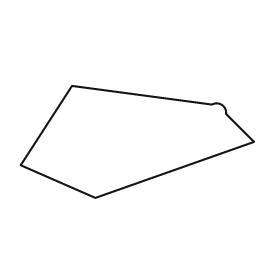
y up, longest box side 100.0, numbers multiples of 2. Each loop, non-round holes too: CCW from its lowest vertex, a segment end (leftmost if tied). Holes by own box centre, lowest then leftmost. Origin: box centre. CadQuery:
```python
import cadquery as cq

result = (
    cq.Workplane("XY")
    .moveTo(-18.0, -24.0)
    .lineTo(50.0, 0.0)
    .lineTo(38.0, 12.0)
    .threePointArc((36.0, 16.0), (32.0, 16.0))
    .lineTo(-28.0, 24.0)
    .lineTo(-50.0, -10.0)
    .close()
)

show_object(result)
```